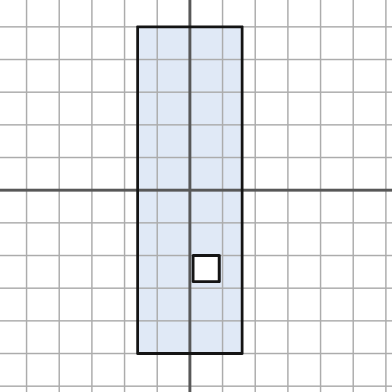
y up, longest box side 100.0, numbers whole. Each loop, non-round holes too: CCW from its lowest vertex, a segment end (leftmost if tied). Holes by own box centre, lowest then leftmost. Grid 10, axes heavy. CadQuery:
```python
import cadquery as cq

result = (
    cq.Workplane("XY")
    .moveTo(-16.0, -50.0)
    .lineTo(16.0, -50.0)
    .lineTo(16.0, 50.0)
    .lineTo(-16.0, 50.0)
    .close()
    .moveTo(1.0, -28.0)
    .lineTo(9.0, -28.0)
    .lineTo(9.0, -20.0)
    .lineTo(1.0, -20.0)
    .close()
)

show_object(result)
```